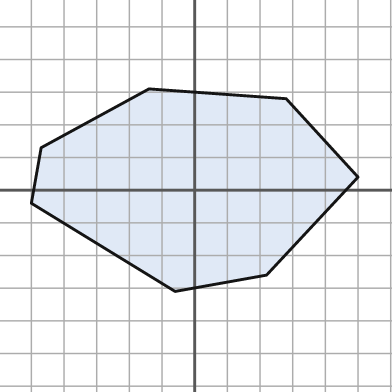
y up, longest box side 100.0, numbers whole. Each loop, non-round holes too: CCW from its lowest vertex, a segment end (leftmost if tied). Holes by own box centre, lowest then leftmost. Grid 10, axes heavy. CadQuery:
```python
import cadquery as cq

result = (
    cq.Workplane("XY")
    .moveTo(-6.0, -31.0)
    .lineTo(22.0, -26.0)
    .lineTo(50.0, 4.0)
    .lineTo(28.0, 28.0)
    .lineTo(-14.0, 31.0)
    .lineTo(-47.0, 13.0)
    .lineTo(-50.0, -4.0)
    .close()
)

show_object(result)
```